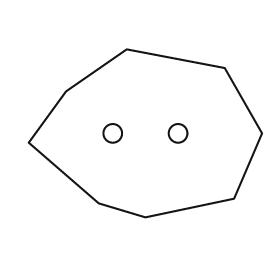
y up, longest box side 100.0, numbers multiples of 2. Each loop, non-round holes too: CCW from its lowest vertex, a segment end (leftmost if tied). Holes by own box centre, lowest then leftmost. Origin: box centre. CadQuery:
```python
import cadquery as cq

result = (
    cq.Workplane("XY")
    .moveTo(0.0, -36.0)
    .lineTo(38.0, -28.0)
    .lineTo(50.0, 0.0)
    .lineTo(34.0, 28.0)
    .lineTo(-8.0, 36.0)
    .lineTo(-34.0, 18.0)
    .lineTo(-50.0, -4.0)
    .lineTo(-20.0, -30.0)
    .close()
    .moveTo(-14.0, 0.0)
    .circle(4.0)
    .moveTo(14.0, 0.0)
    .circle(4.0)
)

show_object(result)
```